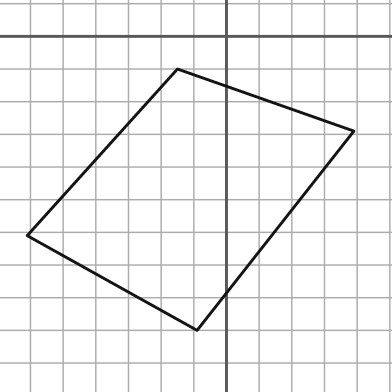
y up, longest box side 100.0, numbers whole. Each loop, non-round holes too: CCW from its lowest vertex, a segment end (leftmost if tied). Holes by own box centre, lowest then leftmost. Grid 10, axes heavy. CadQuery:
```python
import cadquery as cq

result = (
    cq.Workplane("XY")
    .moveTo(-9.0, -90.0)
    .lineTo(39.0, -29.0)
    .lineTo(-15.0, -10.0)
    .lineTo(-61.0, -61.0)
    .close()
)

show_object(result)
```